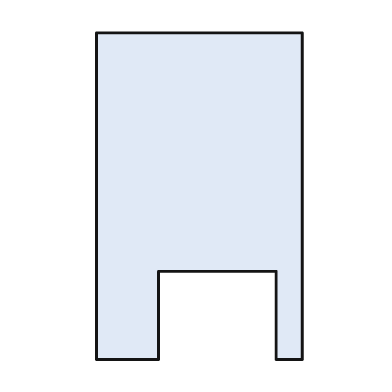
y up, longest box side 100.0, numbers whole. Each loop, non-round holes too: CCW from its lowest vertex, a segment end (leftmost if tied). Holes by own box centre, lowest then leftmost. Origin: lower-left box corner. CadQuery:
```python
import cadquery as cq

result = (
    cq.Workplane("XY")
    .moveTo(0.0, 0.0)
    .lineTo(19.0, 0.0)
    .lineTo(19.0, 27.0)
    .lineTo(55.0, 27.0)
    .lineTo(55.0, 0.0)
    .lineTo(63.0, 0.0)
    .lineTo(63.0, 100.0)
    .lineTo(0.0, 100.0)
    .close()
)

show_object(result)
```